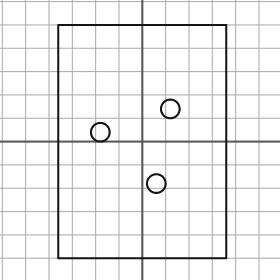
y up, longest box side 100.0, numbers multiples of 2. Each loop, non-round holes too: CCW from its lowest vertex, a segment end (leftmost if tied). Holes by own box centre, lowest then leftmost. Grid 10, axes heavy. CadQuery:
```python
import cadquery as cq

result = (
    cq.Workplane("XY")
    .moveTo(-36.0, -50.0)
    .lineTo(36.0, -50.0)
    .lineTo(36.0, 50.0)
    .lineTo(-36.0, 50.0)
    .close()
    .moveTo(6.0, -18.0)
    .circle(4.0)
    .moveTo(-18.0, 4.0)
    .circle(4.0)
    .moveTo(12.0, 14.0)
    .circle(4.0)
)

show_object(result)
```